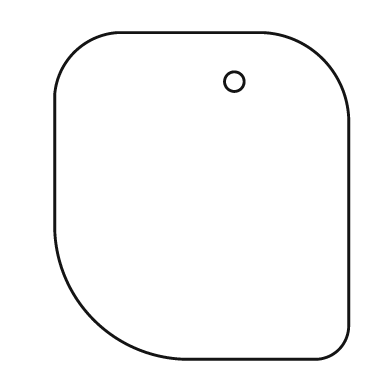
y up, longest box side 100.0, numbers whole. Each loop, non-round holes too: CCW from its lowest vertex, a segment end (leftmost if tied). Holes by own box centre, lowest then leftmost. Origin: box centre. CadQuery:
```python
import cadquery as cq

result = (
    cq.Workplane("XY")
    .moveTo(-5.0, -50.0)
    .lineTo(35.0, -50.0)
    .threePointArc((42.0, -47.0), (45.0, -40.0))
    .lineTo(45.0, 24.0)
    .threePointArc((37.0, 42.0), (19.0, 50.0))
    .lineTo(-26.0, 50.0)
    .threePointArc((-39.0, 44.0), (-45.0, 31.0))
    .lineTo(-45.0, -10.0)
    .threePointArc((-33.0, -38.0), (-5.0, -50.0))
    .close()
    .moveTo(10.0, 35.0)
    .circle(3.0)
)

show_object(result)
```